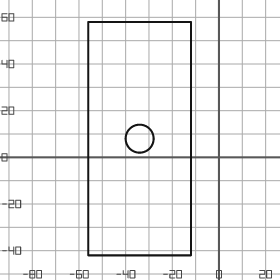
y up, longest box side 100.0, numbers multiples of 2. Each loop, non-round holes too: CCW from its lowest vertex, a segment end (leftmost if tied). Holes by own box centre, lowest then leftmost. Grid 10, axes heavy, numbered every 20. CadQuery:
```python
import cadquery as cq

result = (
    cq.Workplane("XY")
    .moveTo(-56.0, -42.0)
    .lineTo(-12.0, -42.0)
    .lineTo(-12.0, 58.0)
    .lineTo(-56.0, 58.0)
    .close()
    .moveTo(-34.0, 8.0)
    .circle(6.0)
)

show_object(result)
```